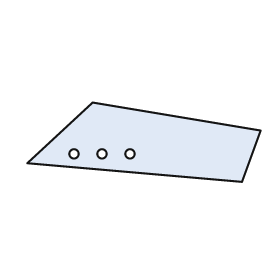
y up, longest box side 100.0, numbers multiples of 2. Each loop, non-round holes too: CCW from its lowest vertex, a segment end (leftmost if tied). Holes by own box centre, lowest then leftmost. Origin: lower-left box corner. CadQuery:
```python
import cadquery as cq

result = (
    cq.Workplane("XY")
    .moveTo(92.0, 0.0)
    .lineTo(100.0, 22.0)
    .lineTo(28.0, 34.0)
    .lineTo(0.0, 8.0)
    .close()
    .moveTo(20.0, 12.0)
    .circle(2.0)
    .moveTo(32.0, 12.0)
    .circle(2.0)
    .moveTo(44.0, 12.0)
    .circle(2.0)
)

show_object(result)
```